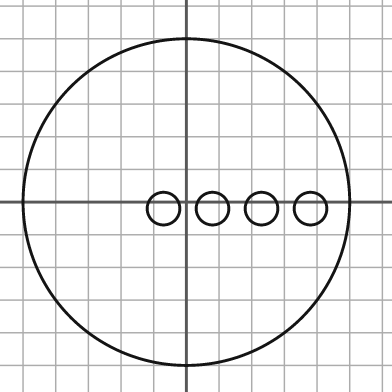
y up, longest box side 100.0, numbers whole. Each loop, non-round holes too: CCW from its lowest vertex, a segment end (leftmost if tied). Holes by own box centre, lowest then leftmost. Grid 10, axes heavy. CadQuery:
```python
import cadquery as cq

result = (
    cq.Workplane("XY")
    .moveTo(0.0, 0.0)
    .circle(50.0)
    .moveTo(-7.0, -2.0)
    .circle(5.0)
    .moveTo(8.0, -2.0)
    .circle(5.0)
    .moveTo(23.0, -2.0)
    .circle(5.0)
    .moveTo(38.0, -2.0)
    .circle(5.0)
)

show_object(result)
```